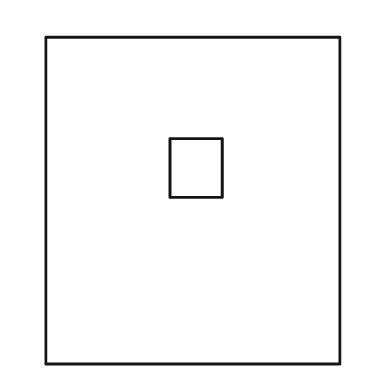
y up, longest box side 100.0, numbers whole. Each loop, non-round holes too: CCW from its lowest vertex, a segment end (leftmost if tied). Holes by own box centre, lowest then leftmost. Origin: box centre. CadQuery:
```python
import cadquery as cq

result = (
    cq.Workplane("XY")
    .moveTo(-45.0, -50.0)
    .lineTo(45.0, -50.0)
    .lineTo(45.0, 50.0)
    .lineTo(-45.0, 50.0)
    .close()
    .moveTo(-7.0, 1.0)
    .lineTo(9.0, 1.0)
    .lineTo(9.0, 19.0)
    .lineTo(-7.0, 19.0)
    .close()
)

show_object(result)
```